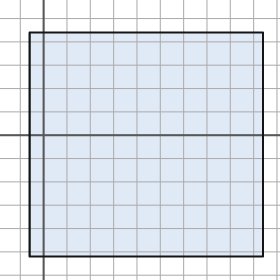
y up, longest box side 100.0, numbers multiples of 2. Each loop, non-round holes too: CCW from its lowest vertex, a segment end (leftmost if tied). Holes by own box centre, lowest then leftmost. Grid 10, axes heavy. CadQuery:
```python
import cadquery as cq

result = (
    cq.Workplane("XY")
    .moveTo(-6.0, -52.0)
    .lineTo(94.0, -52.0)
    .lineTo(94.0, 44.0)
    .lineTo(-6.0, 44.0)
    .close()
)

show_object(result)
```